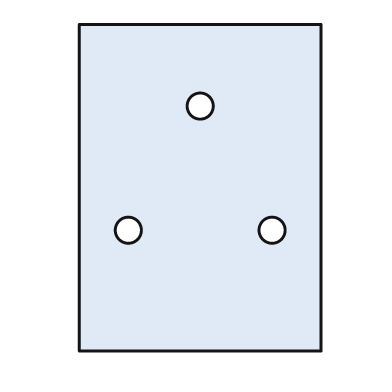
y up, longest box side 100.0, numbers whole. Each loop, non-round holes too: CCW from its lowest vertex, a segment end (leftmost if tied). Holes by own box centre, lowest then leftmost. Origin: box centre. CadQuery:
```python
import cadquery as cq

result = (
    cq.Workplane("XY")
    .moveTo(-37.0, -50.0)
    .lineTo(37.0, -50.0)
    .lineTo(37.0, 50.0)
    .lineTo(-37.0, 50.0)
    .close()
    .moveTo(-22.0, -13.0)
    .circle(4.0)
    .moveTo(22.0, -13.0)
    .circle(4.0)
    .moveTo(0.0, 25.0)
    .circle(4.0)
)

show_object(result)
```